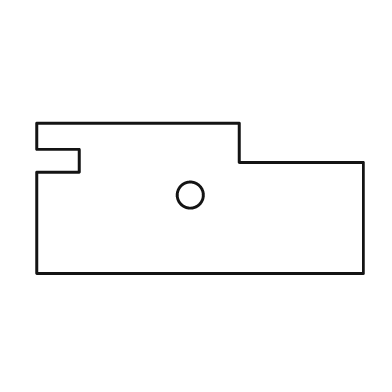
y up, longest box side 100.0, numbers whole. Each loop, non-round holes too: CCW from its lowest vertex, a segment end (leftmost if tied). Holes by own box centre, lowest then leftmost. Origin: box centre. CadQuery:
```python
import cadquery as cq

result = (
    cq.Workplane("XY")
    .moveTo(-50.0, -23.0)
    .lineTo(50.0, -23.0)
    .lineTo(50.0, 11.0)
    .lineTo(12.0, 11.0)
    .lineTo(12.0, 23.0)
    .lineTo(-50.0, 23.0)
    .lineTo(-50.0, 15.0)
    .lineTo(-37.0, 15.0)
    .lineTo(-37.0, 8.0)
    .lineTo(-50.0, 8.0)
    .close()
    .moveTo(-3.0, 1.0)
    .circle(4.0)
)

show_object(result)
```